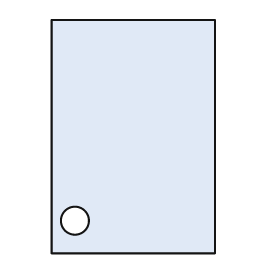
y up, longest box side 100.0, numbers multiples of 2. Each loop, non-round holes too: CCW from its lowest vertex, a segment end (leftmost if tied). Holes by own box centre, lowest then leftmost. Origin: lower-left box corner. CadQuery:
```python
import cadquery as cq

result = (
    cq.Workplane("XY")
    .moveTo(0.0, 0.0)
    .lineTo(70.0, 0.0)
    .lineTo(70.0, 100.0)
    .lineTo(0.0, 100.0)
    .close()
    .moveTo(10.0, 14.0)
    .circle(6.0)
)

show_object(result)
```